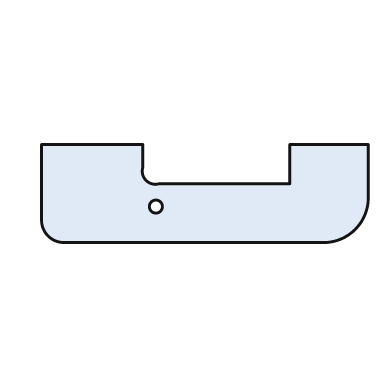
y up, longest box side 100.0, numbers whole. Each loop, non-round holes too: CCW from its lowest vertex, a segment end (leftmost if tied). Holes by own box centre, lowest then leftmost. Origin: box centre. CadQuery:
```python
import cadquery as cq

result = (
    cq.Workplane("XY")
    .moveTo(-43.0, -15.0)
    .lineTo(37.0, -15.0)
    .threePointArc((46.0, -11.0), (50.0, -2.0))
    .lineTo(50.0, 15.0)
    .lineTo(26.0, 15.0)
    .lineTo(26.0, 3.0)
    .lineTo(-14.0, 3.0)
    .threePointArc((-18.0, 4.0), (-19.0, 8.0))
    .lineTo(-19.0, 15.0)
    .lineTo(-50.0, 15.0)
    .lineTo(-50.0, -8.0)
    .threePointArc((-48.0, -13.0), (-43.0, -15.0))
    .close()
    .moveTo(-15.0, -4.0)
    .circle(2.0)
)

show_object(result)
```